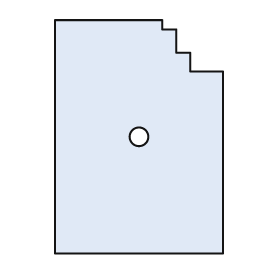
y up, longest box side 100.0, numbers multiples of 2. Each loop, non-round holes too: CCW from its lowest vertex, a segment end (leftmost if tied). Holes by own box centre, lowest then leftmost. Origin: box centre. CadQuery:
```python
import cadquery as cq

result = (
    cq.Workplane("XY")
    .moveTo(-36.0, -50.0)
    .lineTo(36.0, -50.0)
    .lineTo(36.0, 28.0)
    .lineTo(22.0, 28.0)
    .lineTo(22.0, 36.0)
    .lineTo(16.0, 36.0)
    .lineTo(16.0, 46.0)
    .lineTo(10.0, 46.0)
    .lineTo(10.0, 50.0)
    .lineTo(-36.0, 50.0)
    .close()
    .moveTo(0.0, 0.0)
    .circle(4.0)
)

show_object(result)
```